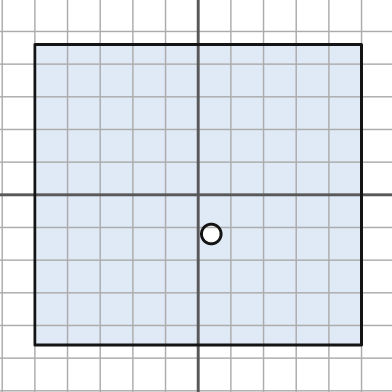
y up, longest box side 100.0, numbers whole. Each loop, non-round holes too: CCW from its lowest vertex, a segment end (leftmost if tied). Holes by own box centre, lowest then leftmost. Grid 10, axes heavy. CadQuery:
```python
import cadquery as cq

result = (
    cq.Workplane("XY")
    .moveTo(-50.0, -46.0)
    .lineTo(50.0, -46.0)
    .lineTo(50.0, 46.0)
    .lineTo(-50.0, 46.0)
    .close()
    .moveTo(4.0, -12.0)
    .circle(3.0)
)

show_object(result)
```